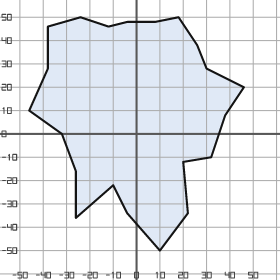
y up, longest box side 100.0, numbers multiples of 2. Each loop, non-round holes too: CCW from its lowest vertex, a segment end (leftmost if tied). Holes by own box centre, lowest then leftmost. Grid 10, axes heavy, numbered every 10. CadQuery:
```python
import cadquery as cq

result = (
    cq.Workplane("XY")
    .moveTo(10.0, -50.0)
    .lineTo(22.0, -34.0)
    .lineTo(20.0, -12.0)
    .lineTo(32.0, -10.0)
    .lineTo(38.0, 8.0)
    .lineTo(46.0, 20.0)
    .lineTo(30.0, 28.0)
    .lineTo(26.0, 38.0)
    .lineTo(18.0, 50.0)
    .lineTo(8.0, 48.0)
    .lineTo(-4.0, 48.0)
    .lineTo(-12.0, 46.0)
    .lineTo(-24.0, 50.0)
    .lineTo(-38.0, 46.0)
    .lineTo(-38.0, 28.0)
    .lineTo(-46.0, 10.0)
    .lineTo(-32.0, 0.0)
    .lineTo(-26.0, -16.0)
    .lineTo(-26.0, -36.0)
    .lineTo(-10.0, -22.0)
    .lineTo(-4.0, -34.0)
    .close()
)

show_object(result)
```